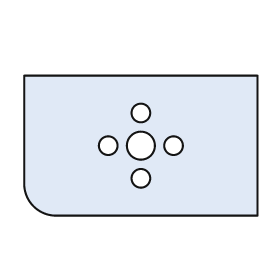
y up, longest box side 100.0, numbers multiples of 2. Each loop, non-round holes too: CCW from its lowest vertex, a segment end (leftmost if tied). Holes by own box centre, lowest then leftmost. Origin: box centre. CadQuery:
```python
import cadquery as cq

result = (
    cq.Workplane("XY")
    .moveTo(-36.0, -30.0)
    .lineTo(50.0, -30.0)
    .lineTo(50.0, 30.0)
    .lineTo(-50.0, 30.0)
    .lineTo(-50.0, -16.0)
    .threePointArc((-46.0, -26.0), (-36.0, -30.0))
    .close()
    .moveTo(0.0, -14.0)
    .circle(4.0)
    .moveTo(-14.0, 0.0)
    .circle(4.0)
    .moveTo(0.0, 0.0)
    .circle(6.0)
    .moveTo(14.0, 0.0)
    .circle(4.0)
    .moveTo(0.0, 14.0)
    .circle(4.0)
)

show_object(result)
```